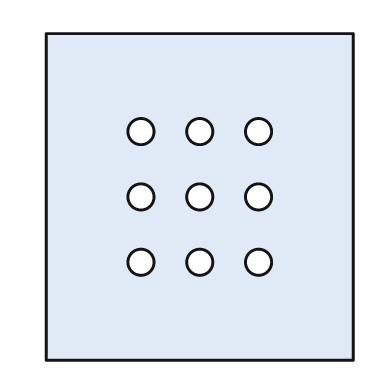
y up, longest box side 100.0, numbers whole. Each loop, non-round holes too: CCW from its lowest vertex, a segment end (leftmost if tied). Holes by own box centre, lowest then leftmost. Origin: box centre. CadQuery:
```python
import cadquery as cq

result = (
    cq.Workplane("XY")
    .moveTo(-47.0, -50.0)
    .lineTo(47.0, -50.0)
    .lineTo(47.0, 50.0)
    .lineTo(-47.0, 50.0)
    .close()
    .moveTo(-18.0, -20.0)
    .circle(4.0)
    .moveTo(0.0, -20.0)
    .circle(4.0)
    .moveTo(18.0, -20.0)
    .circle(4.0)
    .moveTo(-18.0, 0.0)
    .circle(4.0)
    .moveTo(0.0, 0.0)
    .circle(4.0)
    .moveTo(18.0, 0.0)
    .circle(4.0)
    .moveTo(-18.0, 20.0)
    .circle(4.0)
    .moveTo(0.0, 20.0)
    .circle(4.0)
    .moveTo(18.0, 20.0)
    .circle(4.0)
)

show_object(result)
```